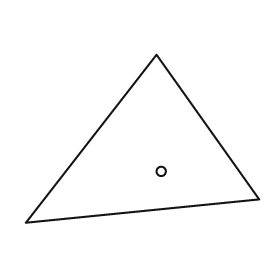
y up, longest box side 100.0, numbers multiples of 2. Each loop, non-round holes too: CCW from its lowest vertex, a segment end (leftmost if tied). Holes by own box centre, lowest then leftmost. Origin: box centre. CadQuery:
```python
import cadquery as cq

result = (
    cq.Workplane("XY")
    .moveTo(-50.0, -36.0)
    .lineTo(50.0, -26.0)
    .lineTo(6.0, 36.0)
    .close()
    .moveTo(8.0, -14.0)
    .circle(2.0)
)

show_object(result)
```